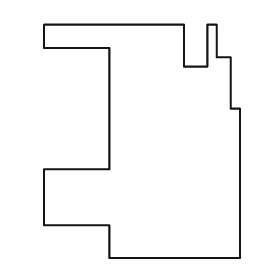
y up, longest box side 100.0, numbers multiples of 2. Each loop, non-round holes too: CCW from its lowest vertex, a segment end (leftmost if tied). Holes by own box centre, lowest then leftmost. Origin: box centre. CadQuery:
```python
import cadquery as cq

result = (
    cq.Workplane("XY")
    .moveTo(-14.0, -50.0)
    .lineTo(42.0, -50.0)
    .lineTo(42.0, 14.0)
    .lineTo(38.0, 14.0)
    .lineTo(38.0, 36.0)
    .lineTo(32.0, 36.0)
    .lineTo(32.0, 50.0)
    .lineTo(28.0, 50.0)
    .lineTo(28.0, 32.0)
    .lineTo(18.0, 32.0)
    .lineTo(18.0, 50.0)
    .lineTo(-42.0, 50.0)
    .lineTo(-42.0, 40.0)
    .lineTo(-14.0, 40.0)
    .lineTo(-14.0, -12.0)
    .lineTo(-42.0, -12.0)
    .lineTo(-42.0, -36.0)
    .lineTo(-14.0, -36.0)
    .close()
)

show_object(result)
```